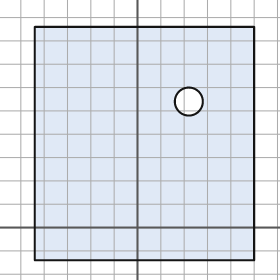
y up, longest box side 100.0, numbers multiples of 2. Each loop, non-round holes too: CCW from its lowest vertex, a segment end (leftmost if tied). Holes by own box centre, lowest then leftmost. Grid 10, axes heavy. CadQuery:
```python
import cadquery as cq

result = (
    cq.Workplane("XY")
    .moveTo(-44.0, -14.0)
    .lineTo(50.0, -14.0)
    .lineTo(50.0, 86.0)
    .lineTo(-44.0, 86.0)
    .close()
    .moveTo(22.0, 54.0)
    .circle(6.0)
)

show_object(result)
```